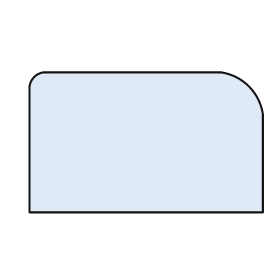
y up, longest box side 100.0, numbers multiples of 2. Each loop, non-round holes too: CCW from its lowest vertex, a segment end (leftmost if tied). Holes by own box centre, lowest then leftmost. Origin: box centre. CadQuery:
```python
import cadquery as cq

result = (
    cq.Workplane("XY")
    .moveTo(-50.0, -30.0)
    .lineTo(50.0, -30.0)
    .lineTo(50.0, 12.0)
    .threePointArc((44.0, 24.0), (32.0, 30.0))
    .lineTo(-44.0, 30.0)
    .threePointArc((-48.0, 28.0), (-50.0, 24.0))
    .close()
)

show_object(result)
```